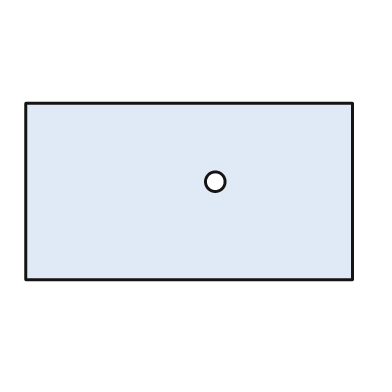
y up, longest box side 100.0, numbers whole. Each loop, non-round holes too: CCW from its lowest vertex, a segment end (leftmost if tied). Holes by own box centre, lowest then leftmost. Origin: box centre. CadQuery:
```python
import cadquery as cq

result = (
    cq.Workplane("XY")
    .moveTo(-50.0, -27.0)
    .lineTo(50.0, -27.0)
    .lineTo(50.0, 27.0)
    .lineTo(-50.0, 27.0)
    .close()
    .moveTo(8.0, 3.0)
    .circle(3.0)
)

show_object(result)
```